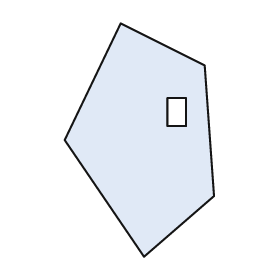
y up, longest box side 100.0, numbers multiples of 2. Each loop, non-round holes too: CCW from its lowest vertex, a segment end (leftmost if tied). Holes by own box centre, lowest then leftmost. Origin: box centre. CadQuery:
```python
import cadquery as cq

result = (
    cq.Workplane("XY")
    .moveTo(2.0, -50.0)
    .lineTo(32.0, -24.0)
    .lineTo(28.0, 32.0)
    .lineTo(-8.0, 50.0)
    .lineTo(-32.0, 0.0)
    .close()
    .moveTo(12.0, 6.0)
    .lineTo(20.0, 6.0)
    .lineTo(20.0, 18.0)
    .lineTo(12.0, 18.0)
    .close()
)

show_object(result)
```